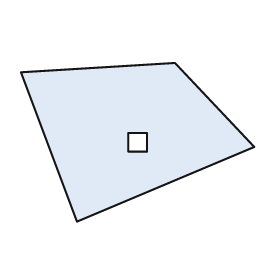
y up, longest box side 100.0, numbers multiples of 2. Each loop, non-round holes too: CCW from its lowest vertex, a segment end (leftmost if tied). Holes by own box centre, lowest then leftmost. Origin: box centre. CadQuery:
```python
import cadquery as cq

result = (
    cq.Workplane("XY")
    .moveTo(-26.0, -34.0)
    .lineTo(50.0, -2.0)
    .lineTo(16.0, 34.0)
    .lineTo(-50.0, 30.0)
    .close()
    .moveTo(-4.0, -4.0)
    .lineTo(4.0, -4.0)
    .lineTo(4.0, 4.0)
    .lineTo(-4.0, 4.0)
    .close()
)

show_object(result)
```